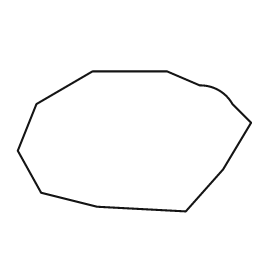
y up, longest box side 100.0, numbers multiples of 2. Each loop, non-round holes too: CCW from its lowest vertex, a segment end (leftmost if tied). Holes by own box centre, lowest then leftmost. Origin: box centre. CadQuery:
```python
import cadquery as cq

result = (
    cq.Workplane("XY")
    .moveTo(22.0, -30.0)
    .lineTo(38.0, -12.0)
    .lineTo(50.0, 8.0)
    .lineTo(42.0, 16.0)
    .threePointArc((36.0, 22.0), (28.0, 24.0))
    .lineTo(14.0, 30.0)
    .lineTo(-18.0, 30.0)
    .lineTo(-42.0, 16.0)
    .lineTo(-50.0, -4.0)
    .lineTo(-40.0, -22.0)
    .lineTo(-16.0, -28.0)
    .close()
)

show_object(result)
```